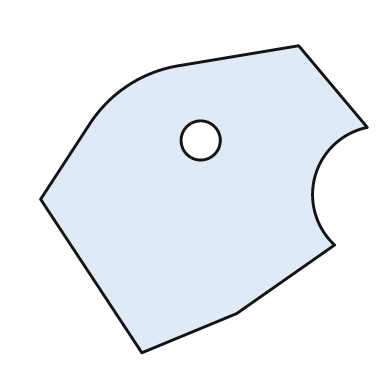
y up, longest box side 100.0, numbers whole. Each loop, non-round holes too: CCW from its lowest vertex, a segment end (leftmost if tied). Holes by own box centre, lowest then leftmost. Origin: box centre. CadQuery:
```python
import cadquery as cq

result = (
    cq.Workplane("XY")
    .moveTo(-19.0, -47.0)
    .lineTo(10.0, -35.0)
    .lineTo(40.0, -14.0)
    .threePointArc((34.0, 7.0), (50.0, 22.0))
    .lineTo(29.0, 47.0)
    .lineTo(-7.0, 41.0)
    .threePointArc((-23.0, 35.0), (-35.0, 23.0))
    .lineTo(-50.0, 0.0)
    .close()
    .moveTo(-1.0, 18.0)
    .circle(6.0)
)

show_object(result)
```